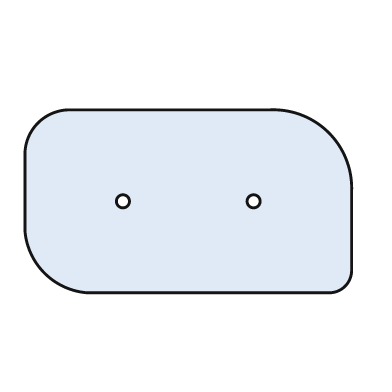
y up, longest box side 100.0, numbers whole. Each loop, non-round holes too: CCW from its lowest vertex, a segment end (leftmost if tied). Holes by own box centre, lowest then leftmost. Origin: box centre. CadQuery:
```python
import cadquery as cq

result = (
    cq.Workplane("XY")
    .moveTo(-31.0, -28.0)
    .lineTo(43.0, -28.0)
    .threePointArc((48.0, -26.0), (50.0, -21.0))
    .lineTo(50.0, 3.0)
    .threePointArc((43.0, 21.0), (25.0, 28.0))
    .lineTo(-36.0, 28.0)
    .threePointArc((-46.0, 24.0), (-50.0, 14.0))
    .lineTo(-50.0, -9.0)
    .threePointArc((-44.0, -22.0), (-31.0, -28.0))
    .close()
    .moveTo(-20.0, 0.0)
    .circle(2.0)
    .moveTo(20.0, 0.0)
    .circle(2.0)
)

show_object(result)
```